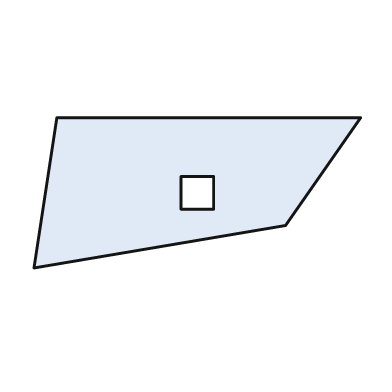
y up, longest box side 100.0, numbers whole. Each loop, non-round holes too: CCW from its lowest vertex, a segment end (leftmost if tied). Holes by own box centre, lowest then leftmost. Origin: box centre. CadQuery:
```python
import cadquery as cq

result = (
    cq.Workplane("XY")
    .moveTo(-50.0, -23.0)
    .lineTo(27.0, -10.0)
    .lineTo(50.0, 23.0)
    .lineTo(-43.0, 23.0)
    .close()
    .moveTo(-5.0, -5.0)
    .lineTo(5.0, -5.0)
    .lineTo(5.0, 5.0)
    .lineTo(-5.0, 5.0)
    .close()
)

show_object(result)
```